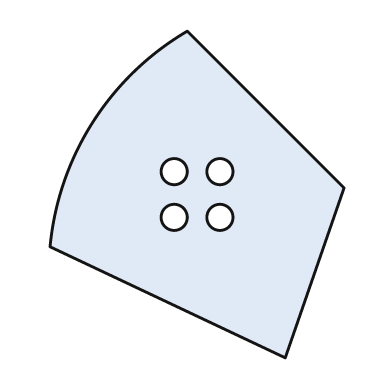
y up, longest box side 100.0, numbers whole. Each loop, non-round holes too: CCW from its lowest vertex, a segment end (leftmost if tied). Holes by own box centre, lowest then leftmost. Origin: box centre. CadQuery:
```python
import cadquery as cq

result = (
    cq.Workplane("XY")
    .moveTo(27.0, -50.0)
    .lineTo(45.0, 2.0)
    .lineTo(-3.0, 50.0)
    .threePointArc((-32.0, 22.0), (-45.0, -16.0))
    .close()
    .moveTo(-7.0, -7.0)
    .circle(4.0)
    .moveTo(7.0, -7.0)
    .circle(4.0)
    .moveTo(-7.0, 7.0)
    .circle(4.0)
    .moveTo(7.0, 7.0)
    .circle(4.0)
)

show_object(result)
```